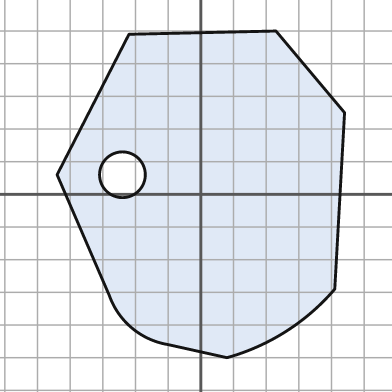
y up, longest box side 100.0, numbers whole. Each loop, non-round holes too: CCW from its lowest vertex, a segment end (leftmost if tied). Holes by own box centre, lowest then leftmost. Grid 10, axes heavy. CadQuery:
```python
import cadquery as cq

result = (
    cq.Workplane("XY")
    .moveTo(8.0, -50.0)
    .threePointArc((26.0, -42.0), (41.0, -29.0))
    .lineTo(44.0, 25.0)
    .lineTo(23.0, 50.0)
    .lineTo(-22.0, 49.0)
    .lineTo(-44.0, 6.0)
    .lineTo(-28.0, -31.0)
    .threePointArc((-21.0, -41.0), (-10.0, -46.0))
    .close()
    .moveTo(-24.0, 6.0)
    .circle(7.0)
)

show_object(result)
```